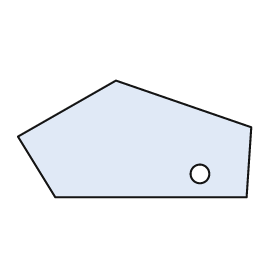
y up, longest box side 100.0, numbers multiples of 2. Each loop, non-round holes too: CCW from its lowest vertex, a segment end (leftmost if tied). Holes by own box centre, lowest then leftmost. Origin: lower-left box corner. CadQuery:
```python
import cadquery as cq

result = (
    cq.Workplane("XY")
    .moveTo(16.0, 0.0)
    .lineTo(98.0, 0.0)
    .lineTo(100.0, 30.0)
    .lineTo(42.0, 50.0)
    .lineTo(0.0, 26.0)
    .close()
    .moveTo(78.0, 10.0)
    .circle(4.0)
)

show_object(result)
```